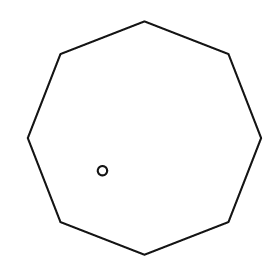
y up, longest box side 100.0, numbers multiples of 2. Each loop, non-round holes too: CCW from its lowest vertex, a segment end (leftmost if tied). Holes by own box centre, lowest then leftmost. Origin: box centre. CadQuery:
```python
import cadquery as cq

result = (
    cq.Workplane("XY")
    .moveTo(0.0, -50.0)
    .lineTo(36.0, -36.0)
    .lineTo(50.0, 0.0)
    .lineTo(36.0, 36.0)
    .lineTo(0.0, 50.0)
    .lineTo(-36.0, 36.0)
    .lineTo(-50.0, 0.0)
    .lineTo(-36.0, -36.0)
    .close()
    .moveTo(-18.0, -14.0)
    .circle(2.0)
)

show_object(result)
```